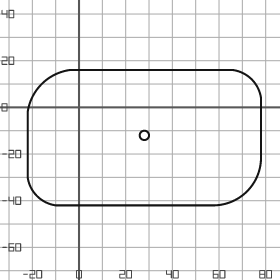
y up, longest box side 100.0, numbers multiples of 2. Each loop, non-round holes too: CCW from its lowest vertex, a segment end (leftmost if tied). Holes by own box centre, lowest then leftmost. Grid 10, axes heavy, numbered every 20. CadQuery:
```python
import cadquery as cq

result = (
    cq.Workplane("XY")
    .moveTo(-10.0, -42.0)
    .lineTo(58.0, -42.0)
    .threePointArc((72.0, -36.0), (78.0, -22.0))
    .lineTo(78.0, 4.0)
    .threePointArc((74.0, 12.0), (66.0, 16.0))
    .lineTo(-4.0, 16.0)
    .threePointArc((-16.0, 10.0), (-22.0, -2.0))
    .lineTo(-22.0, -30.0)
    .threePointArc((-18.0, -38.0), (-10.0, -42.0))
    .close()
    .moveTo(28.0, -12.0)
    .circle(2.0)
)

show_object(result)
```